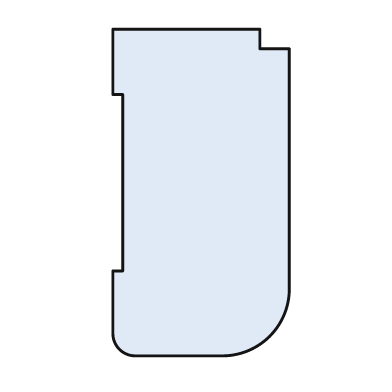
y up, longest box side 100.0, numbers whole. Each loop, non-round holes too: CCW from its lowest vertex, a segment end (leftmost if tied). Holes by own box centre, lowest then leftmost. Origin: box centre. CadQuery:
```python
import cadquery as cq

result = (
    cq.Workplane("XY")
    .moveTo(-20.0, -50.0)
    .lineTo(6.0, -50.0)
    .threePointArc((21.0, -44.0), (27.0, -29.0))
    .lineTo(27.0, 44.0)
    .lineTo(18.0, 44.0)
    .lineTo(18.0, 50.0)
    .lineTo(-27.0, 50.0)
    .lineTo(-27.0, 30.0)
    .lineTo(-24.0, 30.0)
    .lineTo(-24.0, -24.0)
    .lineTo(-27.0, -24.0)
    .lineTo(-27.0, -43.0)
    .threePointArc((-25.0, -48.0), (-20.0, -50.0))
    .close()
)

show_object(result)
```